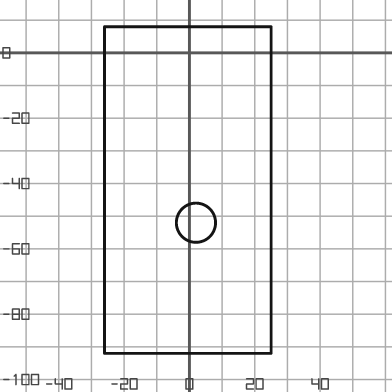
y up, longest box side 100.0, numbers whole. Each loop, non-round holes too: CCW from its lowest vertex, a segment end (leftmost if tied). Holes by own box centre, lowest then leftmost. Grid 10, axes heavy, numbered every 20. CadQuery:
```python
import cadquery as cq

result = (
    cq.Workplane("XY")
    .moveTo(-26.0, -92.0)
    .lineTo(25.0, -92.0)
    .lineTo(25.0, 8.0)
    .lineTo(-26.0, 8.0)
    .close()
    .moveTo(2.0, -52.0)
    .circle(6.0)
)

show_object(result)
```